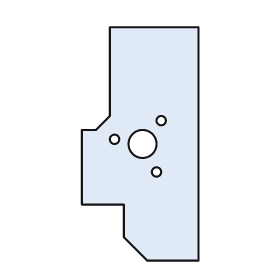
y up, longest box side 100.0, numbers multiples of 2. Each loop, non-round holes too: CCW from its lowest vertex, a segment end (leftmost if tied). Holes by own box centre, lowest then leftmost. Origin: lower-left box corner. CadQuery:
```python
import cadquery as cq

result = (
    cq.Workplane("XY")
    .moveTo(28.0, 0.0)
    .lineTo(50.0, 0.0)
    .lineTo(50.0, 100.0)
    .lineTo(12.0, 100.0)
    .lineTo(12.0, 62.0)
    .lineTo(6.0, 56.0)
    .lineTo(0.0, 56.0)
    .lineTo(0.0, 24.0)
    .lineTo(18.0, 24.0)
    .lineTo(18.0, 10.0)
    .close()
    .moveTo(32.0, 38.0)
    .circle(2.0)
    .moveTo(26.0, 50.0)
    .circle(6.0)
    .moveTo(14.0, 52.0)
    .circle(2.0)
    .moveTo(34.0, 60.0)
    .circle(2.0)
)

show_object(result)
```